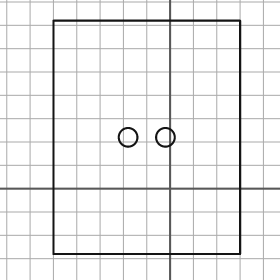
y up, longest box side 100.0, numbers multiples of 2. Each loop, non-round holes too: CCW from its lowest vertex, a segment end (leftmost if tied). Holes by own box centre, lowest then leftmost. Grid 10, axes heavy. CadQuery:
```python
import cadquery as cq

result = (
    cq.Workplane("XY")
    .moveTo(-50.0, -28.0)
    .lineTo(30.0, -28.0)
    .lineTo(30.0, 72.0)
    .lineTo(-50.0, 72.0)
    .close()
    .moveTo(-18.0, 22.0)
    .circle(4.0)
    .moveTo(-2.0, 22.0)
    .circle(4.0)
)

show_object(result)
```